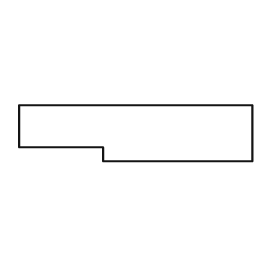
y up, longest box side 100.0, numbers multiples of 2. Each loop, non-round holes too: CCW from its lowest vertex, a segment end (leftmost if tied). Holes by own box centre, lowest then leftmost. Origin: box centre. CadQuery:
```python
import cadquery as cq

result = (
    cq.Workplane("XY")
    .moveTo(-14.0, -12.0)
    .lineTo(50.0, -12.0)
    .lineTo(50.0, 12.0)
    .lineTo(-50.0, 12.0)
    .lineTo(-50.0, -6.0)
    .lineTo(-14.0, -6.0)
    .close()
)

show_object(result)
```